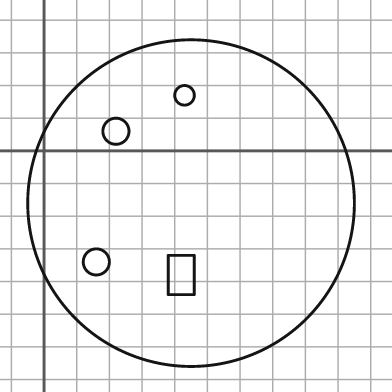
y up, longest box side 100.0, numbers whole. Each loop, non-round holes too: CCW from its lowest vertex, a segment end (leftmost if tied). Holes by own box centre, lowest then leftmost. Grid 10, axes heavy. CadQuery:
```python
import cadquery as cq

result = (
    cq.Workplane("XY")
    .moveTo(45.0, -16.0)
    .circle(50.0)
    .moveTo(38.0, -44.0)
    .lineTo(46.0, -44.0)
    .lineTo(46.0, -32.0)
    .lineTo(38.0, -32.0)
    .close()
    .moveTo(16.0, -34.0)
    .circle(4.0)
    .moveTo(22.0, 6.0)
    .circle(4.0)
    .moveTo(43.0, 17.0)
    .circle(3.0)
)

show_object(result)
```